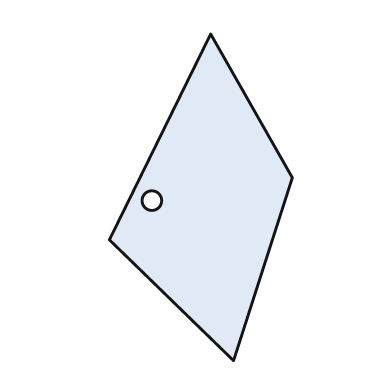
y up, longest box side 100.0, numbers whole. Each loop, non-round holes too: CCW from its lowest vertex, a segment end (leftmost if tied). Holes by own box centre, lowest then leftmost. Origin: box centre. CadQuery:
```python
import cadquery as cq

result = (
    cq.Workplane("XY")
    .moveTo(10.0, -50.0)
    .lineTo(28.0, 6.0)
    .lineTo(3.0, 50.0)
    .lineTo(-28.0, -13.0)
    .close()
    .moveTo(-15.0, -1.0)
    .circle(3.0)
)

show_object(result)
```